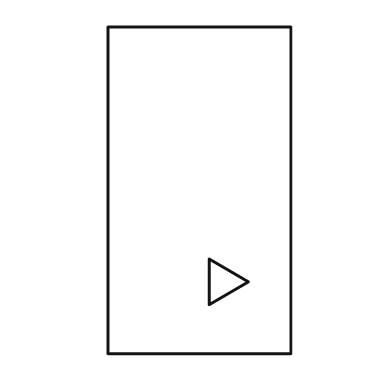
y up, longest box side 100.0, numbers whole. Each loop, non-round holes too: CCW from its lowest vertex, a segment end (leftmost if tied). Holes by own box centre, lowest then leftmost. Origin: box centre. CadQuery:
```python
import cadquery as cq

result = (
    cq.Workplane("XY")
    .moveTo(-28.0, -50.0)
    .lineTo(28.0, -50.0)
    .lineTo(28.0, 50.0)
    .lineTo(-28.0, 50.0)
    .close()
    .moveTo(3.0, -35.0)
    .lineTo(15.0, -28.0)
    .lineTo(3.0, -21.0)
    .close()
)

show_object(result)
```